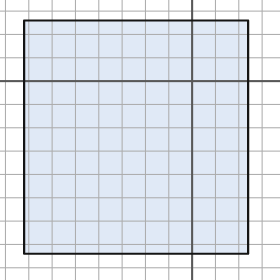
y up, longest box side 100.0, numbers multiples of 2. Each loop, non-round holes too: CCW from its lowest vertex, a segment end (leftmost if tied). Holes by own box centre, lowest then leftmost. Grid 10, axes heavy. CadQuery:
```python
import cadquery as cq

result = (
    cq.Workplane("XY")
    .moveTo(-72.0, -74.0)
    .lineTo(24.0, -74.0)
    .lineTo(24.0, 26.0)
    .lineTo(-72.0, 26.0)
    .close()
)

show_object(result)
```